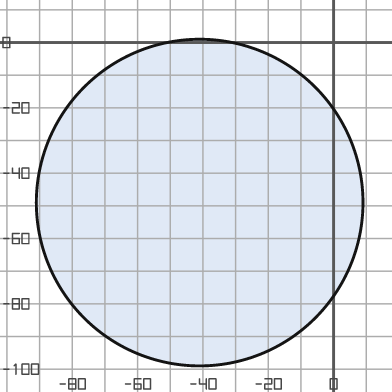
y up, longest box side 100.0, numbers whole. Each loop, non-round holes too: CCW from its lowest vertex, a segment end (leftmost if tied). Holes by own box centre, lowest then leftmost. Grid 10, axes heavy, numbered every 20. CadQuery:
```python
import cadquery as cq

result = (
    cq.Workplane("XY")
    .moveTo(-41.0, -49.0)
    .circle(50.0)
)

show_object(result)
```